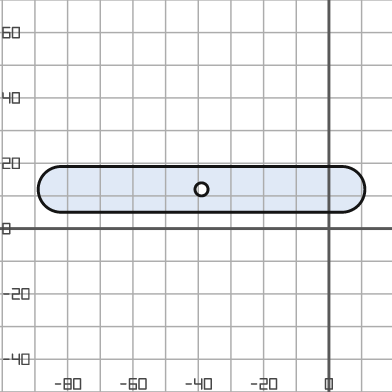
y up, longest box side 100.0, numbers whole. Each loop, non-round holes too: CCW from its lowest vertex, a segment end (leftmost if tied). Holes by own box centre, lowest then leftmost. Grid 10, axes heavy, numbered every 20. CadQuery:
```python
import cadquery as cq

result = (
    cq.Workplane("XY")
    .moveTo(-82.0, 5.0)
    .lineTo(4.0, 5.0)
    .threePointArc((11.0, 12.0), (4.0, 19.0))
    .lineTo(-82.0, 19.0)
    .threePointArc((-89.0, 12.0), (-82.0, 5.0))
    .close()
    .moveTo(-39.0, 12.0)
    .circle(2.0)
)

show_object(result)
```